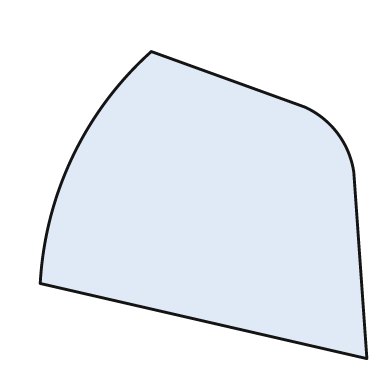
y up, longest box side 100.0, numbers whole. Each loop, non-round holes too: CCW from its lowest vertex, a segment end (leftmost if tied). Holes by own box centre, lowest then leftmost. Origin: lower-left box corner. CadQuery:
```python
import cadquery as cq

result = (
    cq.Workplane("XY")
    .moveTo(100.0, 0.0)
    .lineTo(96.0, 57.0)
    .threePointArc((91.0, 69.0), (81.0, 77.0))
    .lineTo(34.0, 94.0)
    .threePointArc((10.0, 62.0), (0.0, 23.0))
    .close()
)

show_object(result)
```